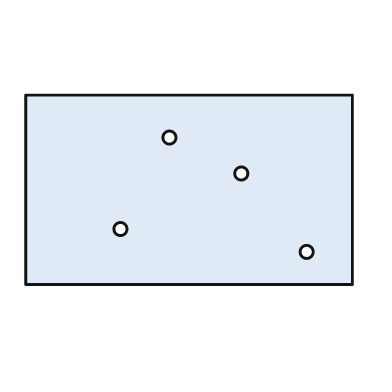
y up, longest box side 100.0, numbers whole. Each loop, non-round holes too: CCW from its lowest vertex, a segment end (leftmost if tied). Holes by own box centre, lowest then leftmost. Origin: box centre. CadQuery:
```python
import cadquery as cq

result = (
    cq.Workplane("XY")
    .moveTo(-50.0, -29.0)
    .lineTo(50.0, -29.0)
    .lineTo(50.0, 29.0)
    .lineTo(-50.0, 29.0)
    .close()
    .moveTo(36.0, -19.0)
    .circle(2.0)
    .moveTo(-21.0, -12.0)
    .circle(2.0)
    .moveTo(16.0, 5.0)
    .circle(2.0)
    .moveTo(-6.0, 16.0)
    .circle(2.0)
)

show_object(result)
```